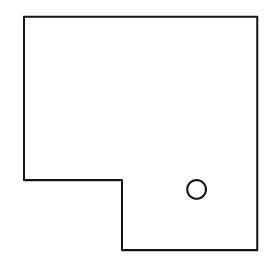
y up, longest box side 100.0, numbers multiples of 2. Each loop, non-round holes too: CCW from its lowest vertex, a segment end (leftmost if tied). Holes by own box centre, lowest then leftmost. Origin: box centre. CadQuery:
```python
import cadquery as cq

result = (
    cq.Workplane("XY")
    .moveTo(-8.0, -50.0)
    .lineTo(50.0, -50.0)
    .lineTo(50.0, 50.0)
    .lineTo(-50.0, 50.0)
    .lineTo(-50.0, -20.0)
    .lineTo(-8.0, -20.0)
    .close()
    .moveTo(24.0, -24.0)
    .circle(4.0)
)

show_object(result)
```